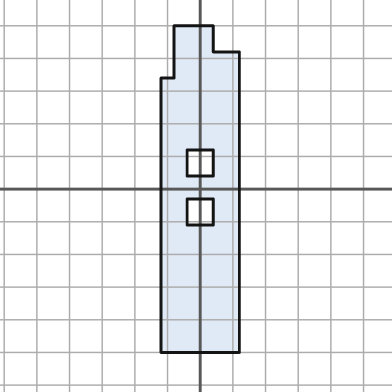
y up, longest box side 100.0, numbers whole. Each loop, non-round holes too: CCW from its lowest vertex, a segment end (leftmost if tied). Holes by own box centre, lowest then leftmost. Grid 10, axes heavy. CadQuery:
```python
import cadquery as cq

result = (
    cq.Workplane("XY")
    .moveTo(-12.0, -50.0)
    .lineTo(12.0, -50.0)
    .lineTo(12.0, 42.0)
    .lineTo(4.0, 42.0)
    .lineTo(4.0, 50.0)
    .lineTo(-8.0, 50.0)
    .lineTo(-8.0, 34.0)
    .lineTo(-12.0, 34.0)
    .close()
    .moveTo(-4.0, -11.0)
    .lineTo(4.0, -11.0)
    .lineTo(4.0, -3.0)
    .lineTo(-4.0, -3.0)
    .close()
    .moveTo(-4.0, 4.0)
    .lineTo(4.0, 4.0)
    .lineTo(4.0, 12.0)
    .lineTo(-4.0, 12.0)
    .close()
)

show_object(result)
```